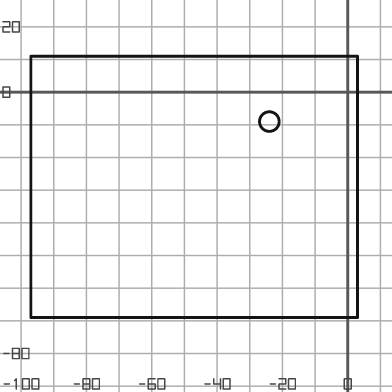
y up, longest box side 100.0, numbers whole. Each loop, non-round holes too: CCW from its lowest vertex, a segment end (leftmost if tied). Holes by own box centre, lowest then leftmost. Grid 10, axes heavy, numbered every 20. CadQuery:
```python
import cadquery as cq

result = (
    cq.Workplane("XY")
    .moveTo(-97.0, -69.0)
    .lineTo(3.0, -69.0)
    .lineTo(3.0, 11.0)
    .lineTo(-97.0, 11.0)
    .close()
    .moveTo(-24.0, -9.0)
    .circle(3.0)
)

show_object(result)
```